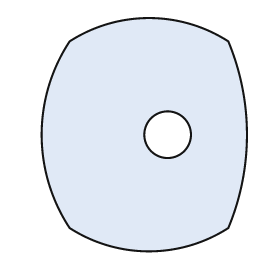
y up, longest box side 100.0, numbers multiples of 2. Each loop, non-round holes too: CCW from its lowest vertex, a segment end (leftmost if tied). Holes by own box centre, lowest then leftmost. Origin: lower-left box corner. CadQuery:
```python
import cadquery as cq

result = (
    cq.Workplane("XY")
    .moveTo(12.0, 10.0)
    .threePointArc((46.0, 0.0), (80.0, 10.0))
    .threePointArc((88.0, 50.0), (80.0, 90.0))
    .threePointArc((46.0, 100.0), (12.0, 90.0))
    .threePointArc((0.0, 50.0), (12.0, 10.0))
    .close()
    .moveTo(54.0, 50.0)
    .circle(10.0)
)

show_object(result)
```